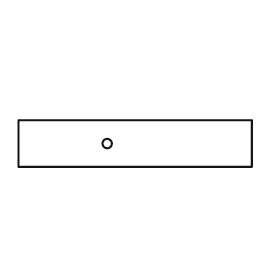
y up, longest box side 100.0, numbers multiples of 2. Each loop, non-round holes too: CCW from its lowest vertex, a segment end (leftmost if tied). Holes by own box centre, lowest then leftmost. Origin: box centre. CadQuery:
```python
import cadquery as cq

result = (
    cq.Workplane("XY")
    .moveTo(-50.0, -10.0)
    .lineTo(50.0, -10.0)
    .lineTo(50.0, 10.0)
    .lineTo(-50.0, 10.0)
    .close()
    .moveTo(-12.0, 0.0)
    .circle(2.0)
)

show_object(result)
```